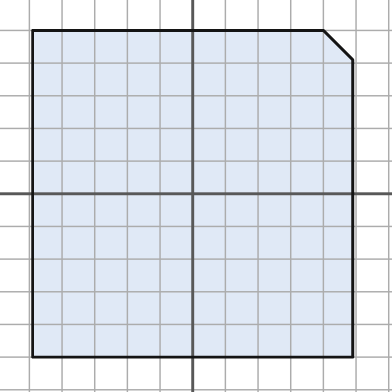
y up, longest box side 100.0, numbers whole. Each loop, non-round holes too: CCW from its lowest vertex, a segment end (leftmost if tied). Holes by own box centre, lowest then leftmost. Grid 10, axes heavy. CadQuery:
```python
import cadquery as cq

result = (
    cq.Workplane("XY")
    .moveTo(-49.0, -50.0)
    .lineTo(49.0, -50.0)
    .lineTo(49.0, 41.0)
    .lineTo(40.0, 50.0)
    .lineTo(-49.0, 50.0)
    .close()
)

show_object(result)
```